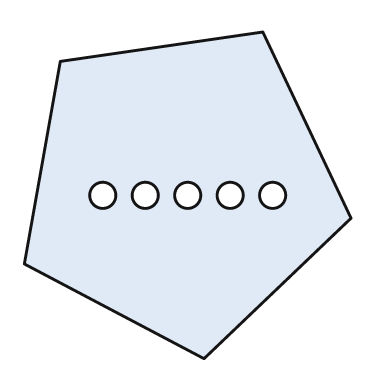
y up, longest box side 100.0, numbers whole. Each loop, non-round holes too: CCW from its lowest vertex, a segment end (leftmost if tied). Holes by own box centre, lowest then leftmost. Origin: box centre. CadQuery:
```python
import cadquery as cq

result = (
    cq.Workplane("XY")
    .moveTo(5.0, -50.0)
    .lineTo(50.0, -7.0)
    .lineTo(23.0, 50.0)
    .lineTo(-39.0, 41.0)
    .lineTo(-50.0, -21.0)
    .close()
    .moveTo(-26.0, 0.0)
    .circle(4.0)
    .moveTo(-13.0, 0.0)
    .circle(4.0)
    .moveTo(0.0, 0.0)
    .circle(4.0)
    .moveTo(13.0, 0.0)
    .circle(4.0)
    .moveTo(26.0, 0.0)
    .circle(4.0)
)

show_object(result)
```